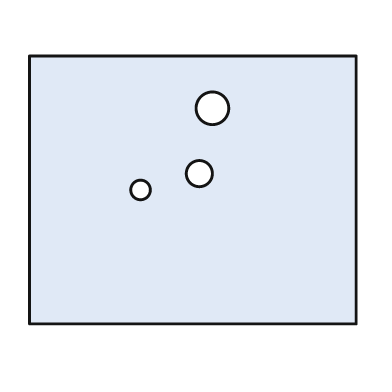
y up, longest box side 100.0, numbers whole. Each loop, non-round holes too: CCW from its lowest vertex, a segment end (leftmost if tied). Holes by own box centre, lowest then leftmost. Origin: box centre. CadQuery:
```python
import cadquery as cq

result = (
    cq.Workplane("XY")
    .moveTo(-50.0, -41.0)
    .lineTo(50.0, -41.0)
    .lineTo(50.0, 41.0)
    .lineTo(-50.0, 41.0)
    .close()
    .moveTo(-16.0, 0.0)
    .circle(3.0)
    .moveTo(2.0, 5.0)
    .circle(4.0)
    .moveTo(6.0, 25.0)
    .circle(5.0)
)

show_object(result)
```